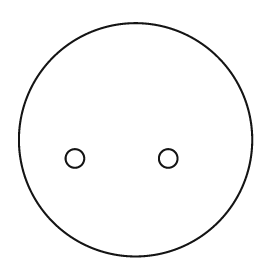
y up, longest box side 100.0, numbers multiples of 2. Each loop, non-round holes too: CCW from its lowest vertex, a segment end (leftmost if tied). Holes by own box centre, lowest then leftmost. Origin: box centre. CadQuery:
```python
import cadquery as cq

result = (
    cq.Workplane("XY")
    .moveTo(0.0, 0.0)
    .circle(50.0)
    .moveTo(-26.0, -8.0)
    .circle(4.0)
    .moveTo(14.0, -8.0)
    .circle(4.0)
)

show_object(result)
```